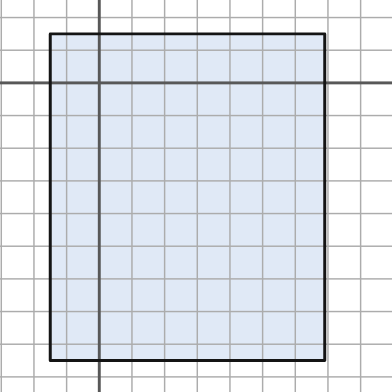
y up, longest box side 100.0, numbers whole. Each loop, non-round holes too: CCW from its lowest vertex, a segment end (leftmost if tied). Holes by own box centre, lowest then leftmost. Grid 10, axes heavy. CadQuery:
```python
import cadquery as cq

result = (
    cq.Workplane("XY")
    .moveTo(-15.0, -85.0)
    .lineTo(69.0, -85.0)
    .lineTo(69.0, 15.0)
    .lineTo(-15.0, 15.0)
    .close()
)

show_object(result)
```